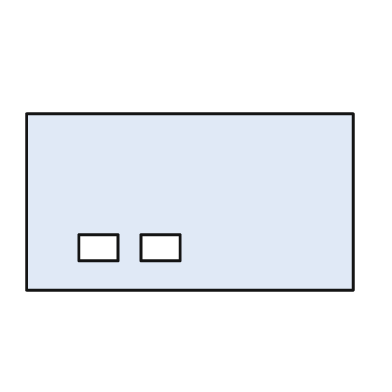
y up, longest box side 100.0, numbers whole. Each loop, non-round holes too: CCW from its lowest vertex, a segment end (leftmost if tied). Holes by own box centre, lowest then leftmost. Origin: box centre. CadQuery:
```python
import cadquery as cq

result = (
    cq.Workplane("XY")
    .moveTo(-50.0, -27.0)
    .lineTo(50.0, -27.0)
    .lineTo(50.0, 27.0)
    .lineTo(-50.0, 27.0)
    .close()
    .moveTo(-34.0, -18.0)
    .lineTo(-22.0, -18.0)
    .lineTo(-22.0, -10.0)
    .lineTo(-34.0, -10.0)
    .close()
    .moveTo(-15.0, -18.0)
    .lineTo(-3.0, -18.0)
    .lineTo(-3.0, -10.0)
    .lineTo(-15.0, -10.0)
    .close()
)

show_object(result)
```